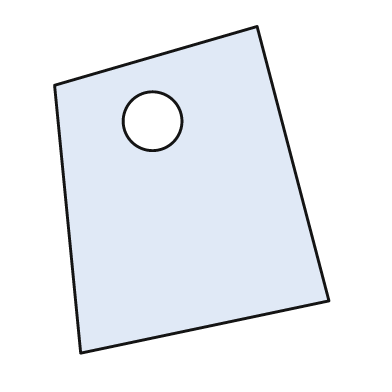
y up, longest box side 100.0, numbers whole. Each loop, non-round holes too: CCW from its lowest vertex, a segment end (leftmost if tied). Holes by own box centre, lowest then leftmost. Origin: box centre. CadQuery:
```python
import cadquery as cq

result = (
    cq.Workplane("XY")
    .moveTo(-34.0, -50.0)
    .lineTo(42.0, -34.0)
    .lineTo(20.0, 50.0)
    .lineTo(-42.0, 32.0)
    .close()
    .moveTo(-12.0, 21.0)
    .circle(9.0)
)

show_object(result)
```